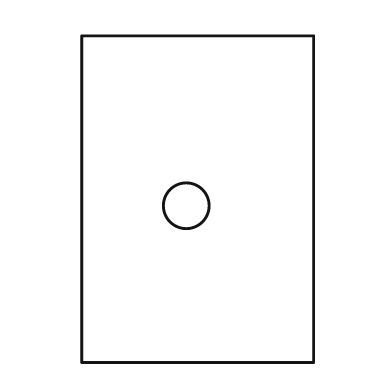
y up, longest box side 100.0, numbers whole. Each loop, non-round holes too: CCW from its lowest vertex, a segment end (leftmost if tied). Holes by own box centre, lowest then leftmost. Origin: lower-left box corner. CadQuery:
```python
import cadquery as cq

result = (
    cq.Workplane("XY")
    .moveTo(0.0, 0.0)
    .lineTo(71.0, 0.0)
    .lineTo(71.0, 100.0)
    .lineTo(0.0, 100.0)
    .close()
    .moveTo(32.0, 48.0)
    .circle(7.0)
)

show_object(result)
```